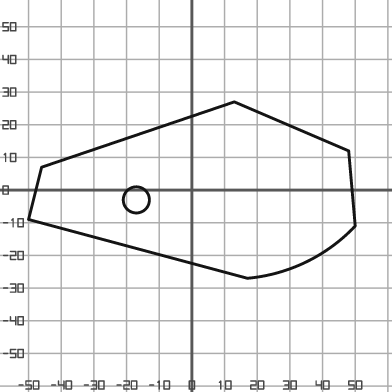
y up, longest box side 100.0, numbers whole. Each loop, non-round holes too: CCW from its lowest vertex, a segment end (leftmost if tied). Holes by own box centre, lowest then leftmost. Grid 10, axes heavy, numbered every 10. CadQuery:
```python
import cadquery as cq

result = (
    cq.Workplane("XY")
    .moveTo(17.0, -27.0)
    .threePointArc((35.0, -22.0), (50.0, -11.0))
    .lineTo(48.0, 12.0)
    .lineTo(13.0, 27.0)
    .lineTo(-46.0, 7.0)
    .lineTo(-50.0, -9.0)
    .close()
    .moveTo(-17.0, -3.0)
    .circle(4.0)
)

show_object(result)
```